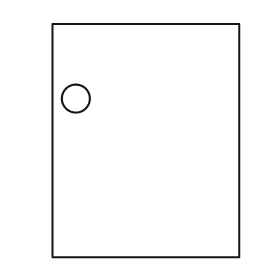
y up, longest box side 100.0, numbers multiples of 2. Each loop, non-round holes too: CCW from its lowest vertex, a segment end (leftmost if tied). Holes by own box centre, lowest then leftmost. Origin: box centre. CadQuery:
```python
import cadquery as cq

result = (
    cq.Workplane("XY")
    .moveTo(-40.0, -50.0)
    .lineTo(40.0, -50.0)
    .lineTo(40.0, 50.0)
    .lineTo(-40.0, 50.0)
    .close()
    .moveTo(-30.0, 18.0)
    .circle(6.0)
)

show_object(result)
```